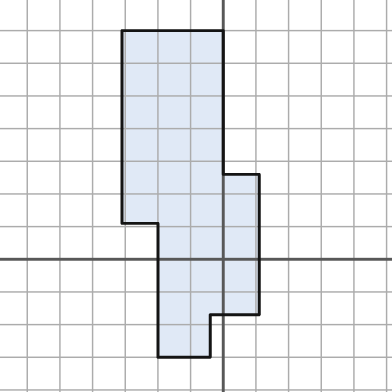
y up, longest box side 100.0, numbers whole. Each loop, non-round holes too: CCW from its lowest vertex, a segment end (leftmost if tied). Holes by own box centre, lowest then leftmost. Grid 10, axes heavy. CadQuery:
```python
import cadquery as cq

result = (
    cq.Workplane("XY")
    .moveTo(-20.0, -30.0)
    .lineTo(-4.0, -30.0)
    .lineTo(-4.0, -17.0)
    .lineTo(11.0, -17.0)
    .lineTo(11.0, 26.0)
    .lineTo(0.0, 26.0)
    .lineTo(0.0, 70.0)
    .lineTo(-31.0, 70.0)
    .lineTo(-31.0, 11.0)
    .lineTo(-20.0, 11.0)
    .close()
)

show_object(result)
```